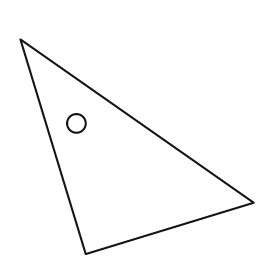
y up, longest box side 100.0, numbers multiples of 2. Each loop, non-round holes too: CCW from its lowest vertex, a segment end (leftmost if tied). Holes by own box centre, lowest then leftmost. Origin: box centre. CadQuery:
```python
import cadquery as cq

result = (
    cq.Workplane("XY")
    .moveTo(-22.0, -46.0)
    .lineTo(50.0, -24.0)
    .lineTo(-50.0, 46.0)
    .close()
    .moveTo(-26.0, 10.0)
    .circle(4.0)
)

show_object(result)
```